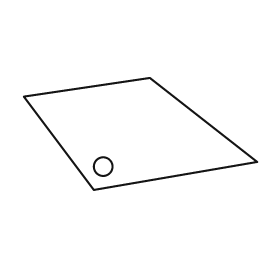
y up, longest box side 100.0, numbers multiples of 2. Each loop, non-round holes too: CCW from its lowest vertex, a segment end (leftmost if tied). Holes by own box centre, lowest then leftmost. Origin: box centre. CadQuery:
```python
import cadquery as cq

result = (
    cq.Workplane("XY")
    .moveTo(-20.0, -24.0)
    .lineTo(50.0, -12.0)
    .lineTo(4.0, 24.0)
    .lineTo(-50.0, 16.0)
    .close()
    .moveTo(-16.0, -14.0)
    .circle(4.0)
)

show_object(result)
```